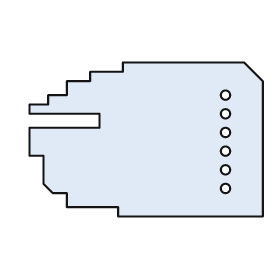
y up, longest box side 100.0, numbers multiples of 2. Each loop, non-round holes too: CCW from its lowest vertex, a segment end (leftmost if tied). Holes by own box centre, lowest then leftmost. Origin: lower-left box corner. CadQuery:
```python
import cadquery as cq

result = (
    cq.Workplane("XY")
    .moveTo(38.0, 0.0)
    .lineTo(100.0, 0.0)
    .lineTo(100.0, 58.0)
    .lineTo(92.0, 66.0)
    .lineTo(40.0, 66.0)
    .lineTo(40.0, 62.0)
    .lineTo(26.0, 62.0)
    .lineTo(26.0, 58.0)
    .lineTo(16.0, 58.0)
    .lineTo(16.0, 52.0)
    .lineTo(8.0, 52.0)
    .lineTo(8.0, 48.0)
    .lineTo(0.0, 48.0)
    .lineTo(0.0, 44.0)
    .lineTo(30.0, 44.0)
    .lineTo(30.0, 38.0)
    .lineTo(0.0, 38.0)
    .lineTo(0.0, 26.0)
    .lineTo(6.0, 26.0)
    .lineTo(6.0, 14.0)
    .lineTo(10.0, 10.0)
    .lineTo(16.0, 10.0)
    .lineTo(16.0, 4.0)
    .lineTo(38.0, 4.0)
    .close()
    .moveTo(84.0, 12.0)
    .circle(2.0)
    .moveTo(84.0, 20.0)
    .circle(2.0)
    .moveTo(84.0, 28.0)
    .circle(2.0)
    .moveTo(84.0, 36.0)
    .circle(2.0)
    .moveTo(84.0, 44.0)
    .circle(2.0)
    .moveTo(84.0, 52.0)
    .circle(2.0)
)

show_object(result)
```